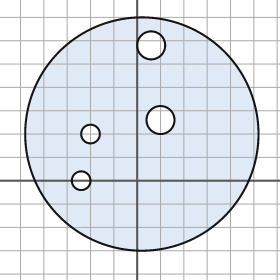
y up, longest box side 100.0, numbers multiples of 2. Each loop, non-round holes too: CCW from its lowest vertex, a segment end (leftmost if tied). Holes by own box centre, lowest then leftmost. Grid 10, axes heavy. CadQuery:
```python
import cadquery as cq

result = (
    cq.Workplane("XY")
    .moveTo(2.0, 20.0)
    .circle(50.0)
    .moveTo(-24.0, 0.0)
    .circle(4.0)
    .moveTo(-20.0, 20.0)
    .circle(4.0)
    .moveTo(10.0, 26.0)
    .circle(6.0)
    .moveTo(6.0, 58.0)
    .circle(6.0)
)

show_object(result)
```